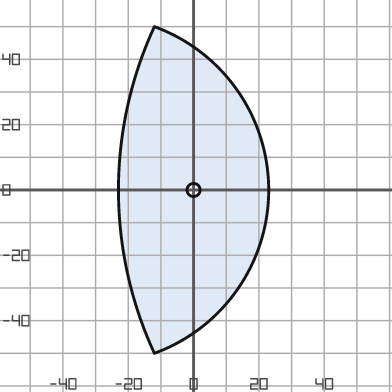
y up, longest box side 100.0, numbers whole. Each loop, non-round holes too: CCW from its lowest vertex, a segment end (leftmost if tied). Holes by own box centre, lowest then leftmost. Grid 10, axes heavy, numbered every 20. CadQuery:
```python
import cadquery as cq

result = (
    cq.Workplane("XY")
    .moveTo(-12.0, -50.0)
    .threePointArc((23.0, 0.0), (-12.0, 50.0))
    .threePointArc((-23.0, 0.0), (-12.0, -50.0))
    .close()
    .moveTo(0.0, 0.0)
    .circle(2.0)
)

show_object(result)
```